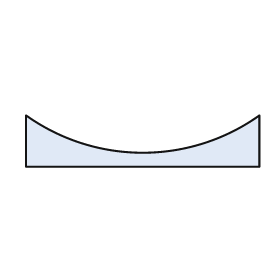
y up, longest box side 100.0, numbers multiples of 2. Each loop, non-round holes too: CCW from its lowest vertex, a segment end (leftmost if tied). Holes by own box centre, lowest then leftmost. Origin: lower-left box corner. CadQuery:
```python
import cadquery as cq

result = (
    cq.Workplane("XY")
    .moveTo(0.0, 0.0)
    .lineTo(100.0, 0.0)
    .lineTo(100.0, 22.0)
    .threePointArc((50.0, 6.0), (0.0, 22.0))
    .close()
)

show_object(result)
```